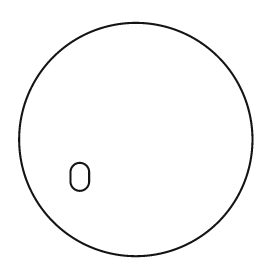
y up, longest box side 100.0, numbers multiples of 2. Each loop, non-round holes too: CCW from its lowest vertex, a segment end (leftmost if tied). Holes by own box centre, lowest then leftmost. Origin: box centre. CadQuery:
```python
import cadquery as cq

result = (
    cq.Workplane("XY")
    .moveTo(0.0, 0.0)
    .circle(50.0)
    .moveTo(-28.0, -18.0)
    .threePointArc((-24.0, -22.0), (-20.0, -18.0))
    .lineTo(-20.0, -14.0)
    .threePointArc((-24.0, -10.0), (-28.0, -14.0))
    .close()
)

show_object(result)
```